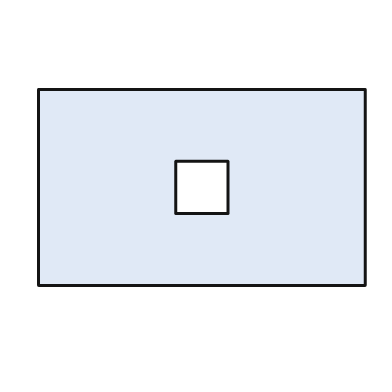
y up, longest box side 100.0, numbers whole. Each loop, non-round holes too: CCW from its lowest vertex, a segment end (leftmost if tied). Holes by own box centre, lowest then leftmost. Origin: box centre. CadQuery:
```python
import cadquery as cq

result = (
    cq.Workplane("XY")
    .moveTo(-50.0, -30.0)
    .lineTo(50.0, -30.0)
    .lineTo(50.0, 30.0)
    .lineTo(-50.0, 30.0)
    .close()
    .moveTo(-8.0, -8.0)
    .lineTo(8.0, -8.0)
    .lineTo(8.0, 8.0)
    .lineTo(-8.0, 8.0)
    .close()
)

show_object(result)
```